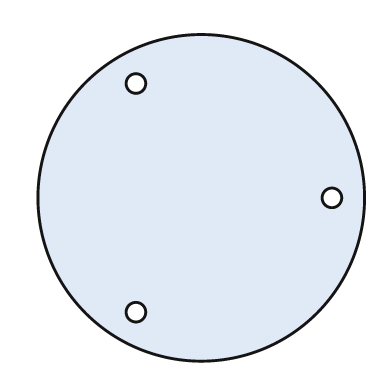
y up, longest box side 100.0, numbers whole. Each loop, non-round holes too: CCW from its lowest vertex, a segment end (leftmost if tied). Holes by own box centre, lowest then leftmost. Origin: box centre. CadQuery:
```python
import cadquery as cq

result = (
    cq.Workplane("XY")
    .moveTo(0.0, 0.0)
    .circle(50.0)
    .moveTo(-20.0, -35.0)
    .circle(3.0)
    .moveTo(40.0, 0.0)
    .circle(3.0)
    .moveTo(-20.0, 35.0)
    .circle(3.0)
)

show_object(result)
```